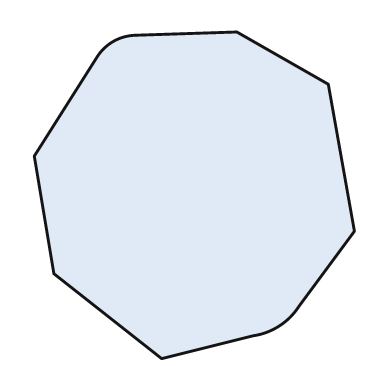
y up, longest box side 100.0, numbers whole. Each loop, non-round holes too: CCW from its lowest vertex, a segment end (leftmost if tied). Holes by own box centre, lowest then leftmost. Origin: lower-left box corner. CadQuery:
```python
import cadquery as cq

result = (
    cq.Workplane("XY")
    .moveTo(39.0, 0.0)
    .lineTo(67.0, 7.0)
    .threePointArc((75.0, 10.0), (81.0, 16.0))
    .lineTo(98.0, 39.0)
    .lineTo(90.0, 84.0)
    .lineTo(62.0, 100.0)
    .lineTo(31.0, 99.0)
    .threePointArc((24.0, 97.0), (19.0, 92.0))
    .lineTo(0.0, 62.0)
    .lineTo(6.0, 26.0)
    .close()
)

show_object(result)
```